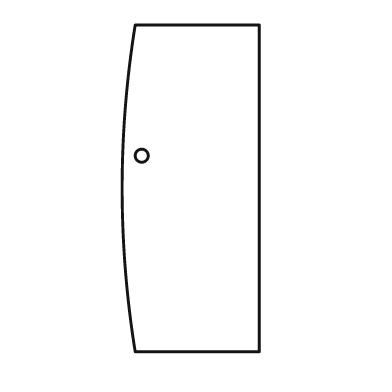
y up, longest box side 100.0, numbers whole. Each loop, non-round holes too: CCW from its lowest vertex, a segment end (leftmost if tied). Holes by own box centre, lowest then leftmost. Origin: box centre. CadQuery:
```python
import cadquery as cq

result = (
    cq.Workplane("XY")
    .moveTo(-17.0, -50.0)
    .lineTo(21.0, -50.0)
    .lineTo(21.0, 50.0)
    .lineTo(-17.0, 50.0)
    .threePointArc((-21.0, 0.0), (-17.0, -50.0))
    .close()
    .moveTo(-15.0, 10.0)
    .circle(2.0)
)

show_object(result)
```